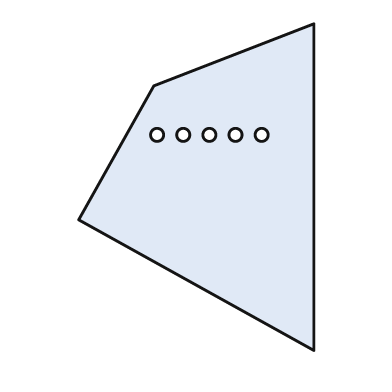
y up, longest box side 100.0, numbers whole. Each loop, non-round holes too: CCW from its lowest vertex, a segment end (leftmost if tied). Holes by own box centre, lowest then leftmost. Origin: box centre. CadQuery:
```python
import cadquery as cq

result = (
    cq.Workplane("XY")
    .moveTo(36.0, -50.0)
    .lineTo(36.0, 50.0)
    .lineTo(-13.0, 31.0)
    .lineTo(-36.0, -10.0)
    .close()
    .moveTo(-12.0, 16.0)
    .circle(2.0)
    .moveTo(-4.0, 16.0)
    .circle(2.0)
    .moveTo(4.0, 16.0)
    .circle(2.0)
    .moveTo(12.0, 16.0)
    .circle(2.0)
    .moveTo(20.0, 16.0)
    .circle(2.0)
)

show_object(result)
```